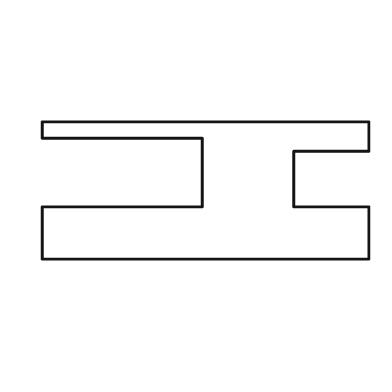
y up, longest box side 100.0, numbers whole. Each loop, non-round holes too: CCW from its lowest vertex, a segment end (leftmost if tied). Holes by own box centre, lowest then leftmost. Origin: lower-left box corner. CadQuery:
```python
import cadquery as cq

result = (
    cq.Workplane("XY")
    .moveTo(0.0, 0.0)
    .lineTo(100.0, 0.0)
    .lineTo(100.0, 16.0)
    .lineTo(77.0, 16.0)
    .lineTo(77.0, 33.0)
    .lineTo(100.0, 33.0)
    .lineTo(100.0, 42.0)
    .lineTo(0.0, 42.0)
    .lineTo(0.0, 37.0)
    .lineTo(49.0, 37.0)
    .lineTo(49.0, 16.0)
    .lineTo(0.0, 16.0)
    .close()
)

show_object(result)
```